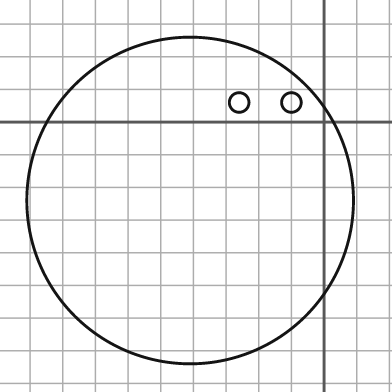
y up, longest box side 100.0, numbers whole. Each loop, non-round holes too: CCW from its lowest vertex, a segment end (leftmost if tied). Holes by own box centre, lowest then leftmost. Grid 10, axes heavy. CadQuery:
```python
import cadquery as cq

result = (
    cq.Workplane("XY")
    .moveTo(-41.0, -24.0)
    .circle(50.0)
    .moveTo(-26.0, 6.0)
    .circle(3.0)
    .moveTo(-10.0, 6.0)
    .circle(3.0)
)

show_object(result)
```